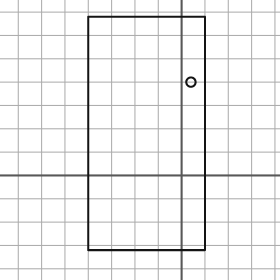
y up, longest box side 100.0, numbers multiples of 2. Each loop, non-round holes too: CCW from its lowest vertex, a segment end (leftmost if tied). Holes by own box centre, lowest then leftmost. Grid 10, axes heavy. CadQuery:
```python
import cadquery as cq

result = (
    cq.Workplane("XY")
    .moveTo(-40.0, -32.0)
    .lineTo(10.0, -32.0)
    .lineTo(10.0, 68.0)
    .lineTo(-40.0, 68.0)
    .close()
    .moveTo(4.0, 40.0)
    .circle(2.0)
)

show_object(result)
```